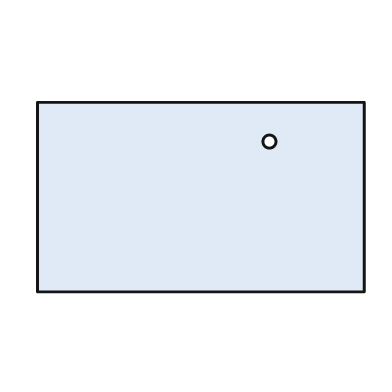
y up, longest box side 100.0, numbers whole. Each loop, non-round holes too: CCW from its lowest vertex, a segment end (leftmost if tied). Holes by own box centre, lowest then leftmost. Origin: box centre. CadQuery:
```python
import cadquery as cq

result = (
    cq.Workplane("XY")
    .moveTo(-50.0, -29.0)
    .lineTo(50.0, -29.0)
    .lineTo(50.0, 29.0)
    .lineTo(-50.0, 29.0)
    .close()
    .moveTo(21.0, 17.0)
    .circle(2.0)
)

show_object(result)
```